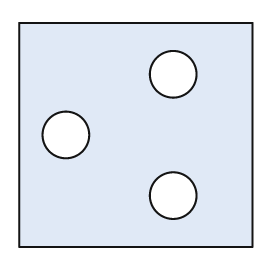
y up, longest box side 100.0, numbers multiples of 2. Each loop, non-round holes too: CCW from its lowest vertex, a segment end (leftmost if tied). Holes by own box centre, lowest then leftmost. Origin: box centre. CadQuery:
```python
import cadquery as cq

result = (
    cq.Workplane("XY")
    .moveTo(-50.0, -48.0)
    .lineTo(50.0, -48.0)
    .lineTo(50.0, 48.0)
    .lineTo(-50.0, 48.0)
    .close()
    .moveTo(16.0, -26.0)
    .circle(10.0)
    .moveTo(-30.0, 0.0)
    .circle(10.0)
    .moveTo(16.0, 26.0)
    .circle(10.0)
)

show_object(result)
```